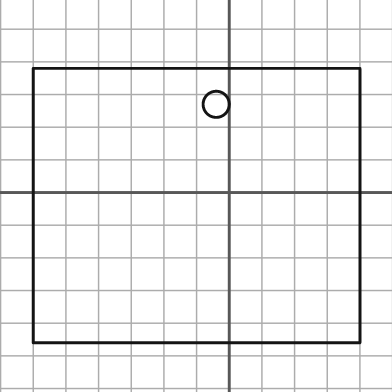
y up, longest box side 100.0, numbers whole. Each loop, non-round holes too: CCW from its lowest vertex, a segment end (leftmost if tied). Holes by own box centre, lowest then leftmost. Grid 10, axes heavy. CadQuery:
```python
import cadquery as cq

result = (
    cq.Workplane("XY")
    .moveTo(-60.0, -46.0)
    .lineTo(40.0, -46.0)
    .lineTo(40.0, 38.0)
    .lineTo(-60.0, 38.0)
    .close()
    .moveTo(-4.0, 27.0)
    .circle(4.0)
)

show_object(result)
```